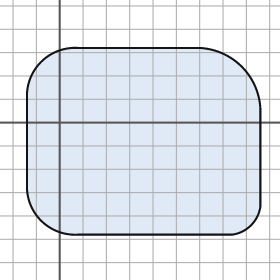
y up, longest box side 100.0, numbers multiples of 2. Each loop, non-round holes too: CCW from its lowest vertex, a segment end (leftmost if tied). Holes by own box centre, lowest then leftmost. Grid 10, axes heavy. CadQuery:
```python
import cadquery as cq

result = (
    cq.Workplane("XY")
    .moveTo(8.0, -48.0)
    .lineTo(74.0, -48.0)
    .threePointArc((82.0, -44.0), (86.0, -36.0))
    .lineTo(86.0, 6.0)
    .threePointArc((78.0, 24.0), (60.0, 32.0))
    .lineTo(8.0, 32.0)
    .threePointArc((-8.0, 26.0), (-14.0, 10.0))
    .lineTo(-14.0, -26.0)
    .threePointArc((-8.0, -42.0), (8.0, -48.0))
    .close()
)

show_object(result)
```